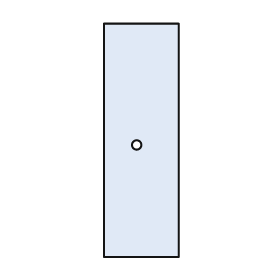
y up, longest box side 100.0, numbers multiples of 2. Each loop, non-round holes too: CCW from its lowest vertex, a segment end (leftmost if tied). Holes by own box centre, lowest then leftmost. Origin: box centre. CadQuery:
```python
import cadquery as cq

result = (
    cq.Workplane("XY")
    .moveTo(-16.0, -50.0)
    .lineTo(16.0, -50.0)
    .lineTo(16.0, 50.0)
    .lineTo(-16.0, 50.0)
    .close()
    .moveTo(-2.0, -2.0)
    .circle(2.0)
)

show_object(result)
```